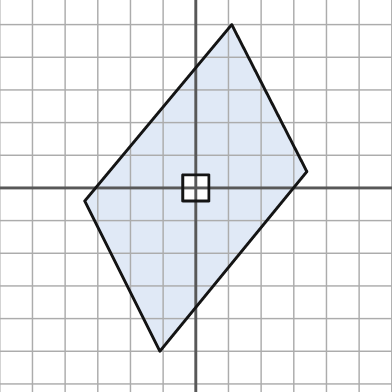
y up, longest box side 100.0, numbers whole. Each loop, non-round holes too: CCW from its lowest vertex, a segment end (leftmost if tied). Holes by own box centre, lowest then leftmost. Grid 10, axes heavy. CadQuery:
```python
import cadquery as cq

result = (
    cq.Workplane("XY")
    .moveTo(-11.0, -50.0)
    .lineTo(34.0, 5.0)
    .lineTo(11.0, 50.0)
    .lineTo(-34.0, -4.0)
    .close()
    .moveTo(-4.0, -4.0)
    .lineTo(4.0, -4.0)
    .lineTo(4.0, 4.0)
    .lineTo(-4.0, 4.0)
    .close()
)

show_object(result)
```